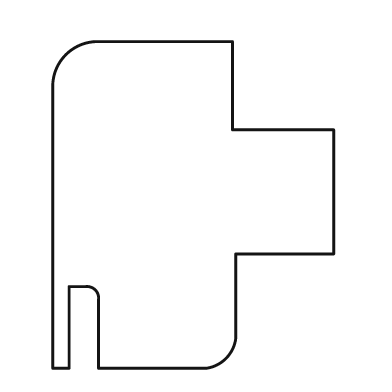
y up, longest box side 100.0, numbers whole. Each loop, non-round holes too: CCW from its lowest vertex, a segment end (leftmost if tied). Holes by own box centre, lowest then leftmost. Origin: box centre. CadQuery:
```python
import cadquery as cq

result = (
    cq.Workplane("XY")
    .moveTo(-43.0, -50.0)
    .lineTo(-38.0, -50.0)
    .lineTo(-38.0, -25.0)
    .lineTo(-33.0, -25.0)
    .threePointArc((-30.0, -26.0), (-29.0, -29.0))
    .lineTo(-29.0, -50.0)
    .lineTo(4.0, -50.0)
    .threePointArc((10.0, -47.0), (13.0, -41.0))
    .lineTo(13.0, -15.0)
    .lineTo(43.0, -15.0)
    .lineTo(43.0, 23.0)
    .lineTo(12.0, 23.0)
    .lineTo(12.0, 50.0)
    .lineTo(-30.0, 50.0)
    .threePointArc((-39.0, 46.0), (-43.0, 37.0))
    .close()
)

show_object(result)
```